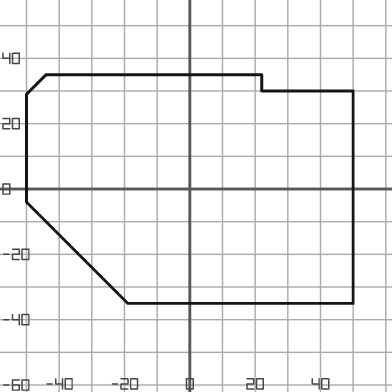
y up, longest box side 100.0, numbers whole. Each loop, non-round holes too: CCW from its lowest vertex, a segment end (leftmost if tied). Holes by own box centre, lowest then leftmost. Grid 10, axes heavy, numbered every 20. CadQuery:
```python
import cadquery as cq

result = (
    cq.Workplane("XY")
    .moveTo(-19.0, -35.0)
    .lineTo(50.0, -35.0)
    .lineTo(50.0, 30.0)
    .lineTo(22.0, 30.0)
    .lineTo(22.0, 35.0)
    .lineTo(-44.0, 35.0)
    .lineTo(-50.0, 29.0)
    .lineTo(-50.0, -4.0)
    .close()
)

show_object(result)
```